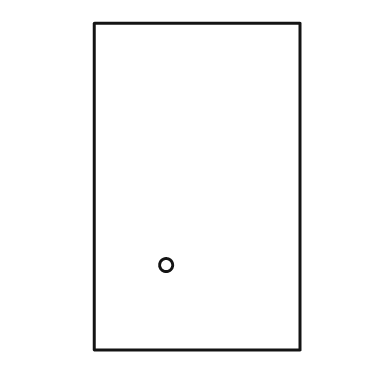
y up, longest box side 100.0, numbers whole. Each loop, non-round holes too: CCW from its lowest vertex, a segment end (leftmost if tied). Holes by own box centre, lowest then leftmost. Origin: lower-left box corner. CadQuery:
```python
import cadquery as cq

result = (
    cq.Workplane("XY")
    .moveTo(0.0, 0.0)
    .lineTo(63.0, 0.0)
    .lineTo(63.0, 100.0)
    .lineTo(0.0, 100.0)
    .close()
    .moveTo(22.0, 26.0)
    .circle(2.0)
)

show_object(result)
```